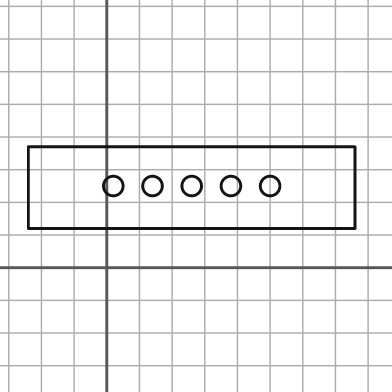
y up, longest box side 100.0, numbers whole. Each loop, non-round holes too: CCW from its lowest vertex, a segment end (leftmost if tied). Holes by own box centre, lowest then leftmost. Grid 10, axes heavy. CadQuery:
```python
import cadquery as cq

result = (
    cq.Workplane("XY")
    .moveTo(-24.0, 12.0)
    .lineTo(76.0, 12.0)
    .lineTo(76.0, 37.0)
    .lineTo(-24.0, 37.0)
    .close()
    .moveTo(2.0, 25.0)
    .circle(3.0)
    .moveTo(14.0, 25.0)
    .circle(3.0)
    .moveTo(26.0, 25.0)
    .circle(3.0)
    .moveTo(38.0, 25.0)
    .circle(3.0)
    .moveTo(50.0, 25.0)
    .circle(3.0)
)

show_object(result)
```